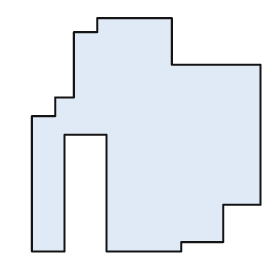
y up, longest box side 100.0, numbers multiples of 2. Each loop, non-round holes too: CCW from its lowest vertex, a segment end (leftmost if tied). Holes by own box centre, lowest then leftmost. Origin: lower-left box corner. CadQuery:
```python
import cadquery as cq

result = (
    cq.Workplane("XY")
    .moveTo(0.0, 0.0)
    .lineTo(14.0, 0.0)
    .lineTo(14.0, 50.0)
    .lineTo(32.0, 50.0)
    .lineTo(32.0, 0.0)
    .lineTo(64.0, 0.0)
    .lineTo(64.0, 4.0)
    .lineTo(82.0, 4.0)
    .lineTo(82.0, 20.0)
    .lineTo(98.0, 20.0)
    .lineTo(98.0, 80.0)
    .lineTo(60.0, 80.0)
    .lineTo(60.0, 100.0)
    .lineTo(28.0, 100.0)
    .lineTo(28.0, 94.0)
    .lineTo(18.0, 94.0)
    .lineTo(18.0, 66.0)
    .lineTo(10.0, 66.0)
    .lineTo(10.0, 58.0)
    .lineTo(0.0, 58.0)
    .close()
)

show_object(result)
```